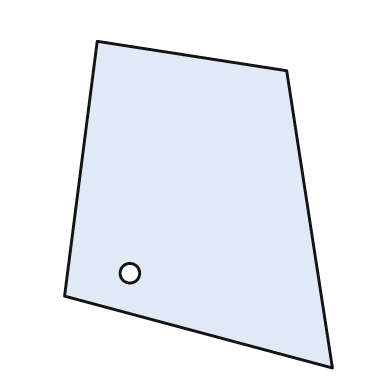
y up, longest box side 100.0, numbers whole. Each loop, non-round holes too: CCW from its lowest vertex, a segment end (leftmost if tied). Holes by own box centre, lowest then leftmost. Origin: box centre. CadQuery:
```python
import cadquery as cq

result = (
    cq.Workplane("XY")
    .moveTo(41.0, -50.0)
    .lineTo(27.0, 41.0)
    .lineTo(-31.0, 50.0)
    .lineTo(-41.0, -28.0)
    .close()
    .moveTo(-21.0, -21.0)
    .circle(3.0)
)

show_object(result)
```